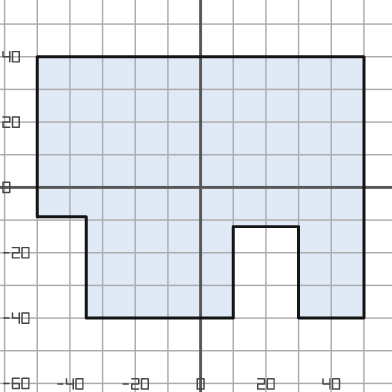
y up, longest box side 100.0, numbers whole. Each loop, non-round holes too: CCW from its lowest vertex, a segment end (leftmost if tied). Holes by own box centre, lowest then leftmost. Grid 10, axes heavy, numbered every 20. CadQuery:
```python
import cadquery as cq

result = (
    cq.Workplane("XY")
    .moveTo(-35.0, -40.0)
    .lineTo(10.0, -40.0)
    .lineTo(10.0, -12.0)
    .lineTo(30.0, -12.0)
    .lineTo(30.0, -40.0)
    .lineTo(50.0, -40.0)
    .lineTo(50.0, 40.0)
    .lineTo(-50.0, 40.0)
    .lineTo(-50.0, -9.0)
    .lineTo(-35.0, -9.0)
    .close()
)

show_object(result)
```